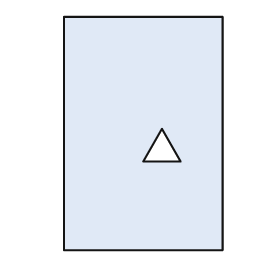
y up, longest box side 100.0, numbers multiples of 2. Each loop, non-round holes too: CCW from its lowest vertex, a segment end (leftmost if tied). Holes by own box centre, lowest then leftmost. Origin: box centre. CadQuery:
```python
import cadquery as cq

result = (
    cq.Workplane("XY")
    .moveTo(-34.0, -50.0)
    .lineTo(34.0, -50.0)
    .lineTo(34.0, 50.0)
    .lineTo(-34.0, 50.0)
    .close()
    .moveTo(0.0, -12.0)
    .lineTo(16.0, -12.0)
    .lineTo(8.0, 2.0)
    .close()
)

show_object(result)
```